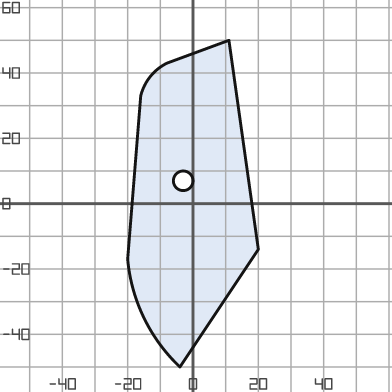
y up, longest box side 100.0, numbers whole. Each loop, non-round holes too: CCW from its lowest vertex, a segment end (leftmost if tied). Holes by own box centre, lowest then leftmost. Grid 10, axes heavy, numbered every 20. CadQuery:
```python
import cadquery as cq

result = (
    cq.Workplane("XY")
    .moveTo(-4.0, -50.0)
    .lineTo(20.0, -14.0)
    .lineTo(11.0, 50.0)
    .lineTo(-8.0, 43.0)
    .threePointArc((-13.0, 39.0), (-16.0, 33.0))
    .lineTo(-20.0, -17.0)
    .threePointArc((-15.0, -35.0), (-4.0, -50.0))
    .close()
    .moveTo(-3.0, 7.0)
    .circle(3.0)
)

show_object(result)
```